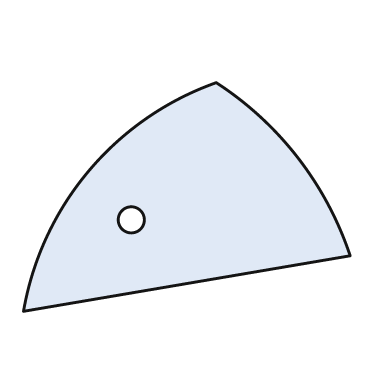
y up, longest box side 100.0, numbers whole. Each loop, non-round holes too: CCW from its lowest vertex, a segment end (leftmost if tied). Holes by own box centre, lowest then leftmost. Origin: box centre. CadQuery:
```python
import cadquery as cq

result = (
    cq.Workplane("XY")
    .moveTo(-50.0, -35.0)
    .lineTo(50.0, -18.0)
    .threePointArc((34.0, 12.0), (9.0, 35.0))
    .threePointArc((-30.0, 8.0), (-50.0, -35.0))
    .close()
    .moveTo(-17.0, -7.0)
    .circle(4.0)
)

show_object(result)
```